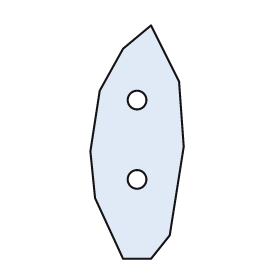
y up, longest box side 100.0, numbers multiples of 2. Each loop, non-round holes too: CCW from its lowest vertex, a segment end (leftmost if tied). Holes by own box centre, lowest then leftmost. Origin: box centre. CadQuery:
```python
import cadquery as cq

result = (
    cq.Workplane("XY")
    .moveTo(-6.0, -50.0)
    .lineTo(6.0, -50.0)
    .lineTo(14.0, -40.0)
    .lineTo(20.0, -2.0)
    .lineTo(18.0, 26.0)
    .lineTo(6.0, 50.0)
    .lineTo(-6.0, 40.0)
    .lineTo(-16.0, 22.0)
    .lineTo(-20.0, -4.0)
    .lineTo(-18.0, -24.0)
    .close()
    .moveTo(0.0, -16.0)
    .circle(4.0)
    .moveTo(0.0, 18.0)
    .circle(4.0)
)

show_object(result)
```